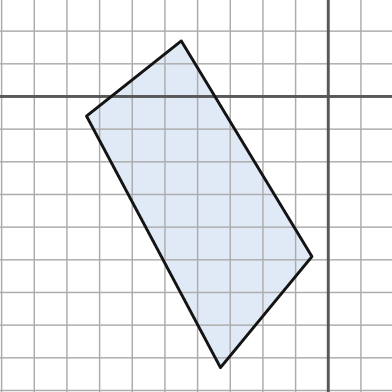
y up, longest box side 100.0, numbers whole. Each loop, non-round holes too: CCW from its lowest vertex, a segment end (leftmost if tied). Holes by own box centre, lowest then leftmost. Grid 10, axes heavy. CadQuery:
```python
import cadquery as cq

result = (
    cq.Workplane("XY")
    .moveTo(-33.0, -83.0)
    .lineTo(-5.0, -49.0)
    .lineTo(-45.0, 17.0)
    .lineTo(-74.0, -6.0)
    .close()
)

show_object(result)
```